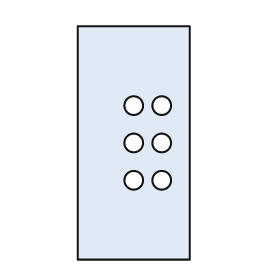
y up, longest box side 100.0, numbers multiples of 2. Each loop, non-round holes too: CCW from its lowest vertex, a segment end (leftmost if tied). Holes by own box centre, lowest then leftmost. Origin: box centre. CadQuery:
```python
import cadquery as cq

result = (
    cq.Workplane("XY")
    .moveTo(-24.0, -50.0)
    .lineTo(24.0, -50.0)
    .lineTo(24.0, 50.0)
    .lineTo(-24.0, 50.0)
    .close()
    .moveTo(0.0, -16.0)
    .circle(4.0)
    .moveTo(12.0, -16.0)
    .circle(4.0)
    .moveTo(0.0, 0.0)
    .circle(4.0)
    .moveTo(12.0, 0.0)
    .circle(4.0)
    .moveTo(0.0, 16.0)
    .circle(4.0)
    .moveTo(12.0, 16.0)
    .circle(4.0)
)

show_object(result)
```